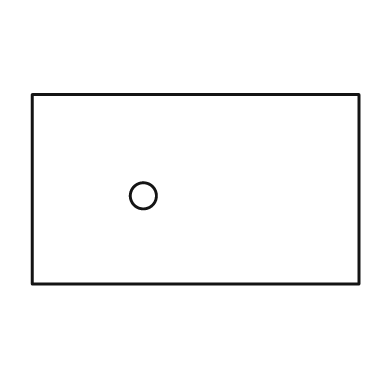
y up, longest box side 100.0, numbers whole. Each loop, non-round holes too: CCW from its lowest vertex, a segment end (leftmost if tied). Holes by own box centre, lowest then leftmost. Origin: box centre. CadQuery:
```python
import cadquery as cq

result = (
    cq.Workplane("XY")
    .moveTo(-50.0, -29.0)
    .lineTo(50.0, -29.0)
    .lineTo(50.0, 29.0)
    .lineTo(-50.0, 29.0)
    .close()
    .moveTo(-16.0, -2.0)
    .circle(4.0)
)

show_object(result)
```